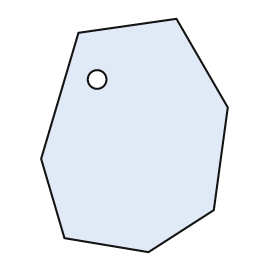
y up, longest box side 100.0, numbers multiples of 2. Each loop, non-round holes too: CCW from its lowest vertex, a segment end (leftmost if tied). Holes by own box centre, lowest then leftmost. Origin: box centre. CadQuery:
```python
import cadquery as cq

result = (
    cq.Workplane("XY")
    .moveTo(6.0, -50.0)
    .lineTo(34.0, -32.0)
    .lineTo(40.0, 12.0)
    .lineTo(18.0, 50.0)
    .lineTo(-24.0, 44.0)
    .lineTo(-40.0, -10.0)
    .lineTo(-30.0, -44.0)
    .close()
    .moveTo(-16.0, 24.0)
    .circle(4.0)
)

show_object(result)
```